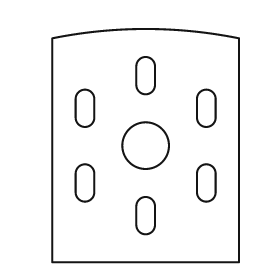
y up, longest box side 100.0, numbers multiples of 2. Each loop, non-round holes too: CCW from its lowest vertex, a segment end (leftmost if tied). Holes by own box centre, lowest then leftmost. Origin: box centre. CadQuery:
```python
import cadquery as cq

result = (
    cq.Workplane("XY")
    .moveTo(-40.0, -50.0)
    .lineTo(40.0, -50.0)
    .lineTo(40.0, 46.0)
    .threePointArc((0.0, 50.0), (-40.0, 46.0))
    .close()
    .moveTo(-4.0, -34.0)
    .threePointArc((0.0, -38.0), (4.0, -34.0))
    .lineTo(4.0, -26.0)
    .threePointArc((0.0, -22.0), (-4.0, -26.0))
    .close()
    .moveTo(-30.0, -20.0)
    .threePointArc((-26.0, -24.0), (-22.0, -20.0))
    .lineTo(-22.0, -12.0)
    .threePointArc((-26.0, -8.0), (-30.0, -12.0))
    .close()
    .moveTo(22.0, -20.0)
    .threePointArc((26.0, -24.0), (30.0, -20.0))
    .lineTo(30.0, -12.0)
    .threePointArc((26.0, -8.0), (22.0, -12.0))
    .close()
    .moveTo(0.0, 0.0)
    .circle(10.0)
    .moveTo(-30.0, 12.0)
    .threePointArc((-26.0, 8.0), (-22.0, 12.0))
    .lineTo(-22.0, 20.0)
    .threePointArc((-26.0, 24.0), (-30.0, 20.0))
    .close()
    .moveTo(22.0, 12.0)
    .threePointArc((26.0, 8.0), (30.0, 12.0))
    .lineTo(30.0, 20.0)
    .threePointArc((26.0, 24.0), (22.0, 20.0))
    .close()
    .moveTo(-4.0, 26.0)
    .threePointArc((0.0, 22.0), (4.0, 26.0))
    .lineTo(4.0, 34.0)
    .threePointArc((0.0, 38.0), (-4.0, 34.0))
    .close()
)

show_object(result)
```